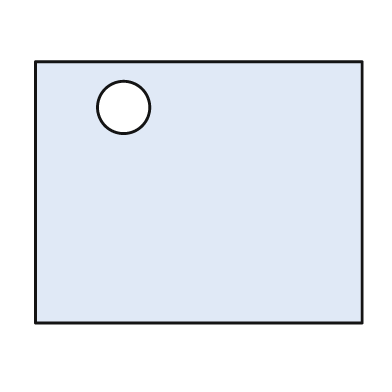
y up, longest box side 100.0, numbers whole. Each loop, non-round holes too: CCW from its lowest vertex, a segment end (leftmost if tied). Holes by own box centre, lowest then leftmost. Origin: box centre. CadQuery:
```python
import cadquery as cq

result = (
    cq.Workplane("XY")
    .moveTo(-50.0, -40.0)
    .lineTo(50.0, -40.0)
    .lineTo(50.0, 40.0)
    .lineTo(-50.0, 40.0)
    .close()
    .moveTo(-23.0, 26.0)
    .circle(8.0)
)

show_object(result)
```